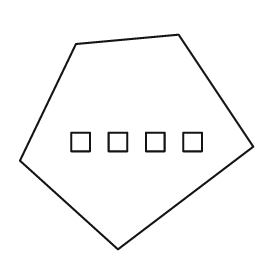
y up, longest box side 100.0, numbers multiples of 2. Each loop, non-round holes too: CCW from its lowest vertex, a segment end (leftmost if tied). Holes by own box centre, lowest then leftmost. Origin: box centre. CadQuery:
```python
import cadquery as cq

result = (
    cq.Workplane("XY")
    .moveTo(-8.0, -46.0)
    .lineTo(50.0, -2.0)
    .lineTo(18.0, 46.0)
    .lineTo(-26.0, 42.0)
    .lineTo(-50.0, -8.0)
    .close()
    .moveTo(-28.0, -4.0)
    .lineTo(-20.0, -4.0)
    .lineTo(-20.0, 4.0)
    .lineTo(-28.0, 4.0)
    .close()
    .moveTo(-12.0, -4.0)
    .lineTo(-4.0, -4.0)
    .lineTo(-4.0, 4.0)
    .lineTo(-12.0, 4.0)
    .close()
    .moveTo(4.0, -4.0)
    .lineTo(12.0, -4.0)
    .lineTo(12.0, 4.0)
    .lineTo(4.0, 4.0)
    .close()
    .moveTo(20.0, -4.0)
    .lineTo(28.0, -4.0)
    .lineTo(28.0, 4.0)
    .lineTo(20.0, 4.0)
    .close()
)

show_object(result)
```